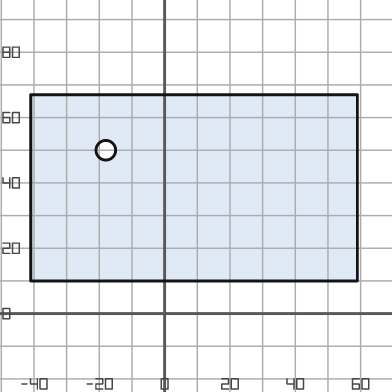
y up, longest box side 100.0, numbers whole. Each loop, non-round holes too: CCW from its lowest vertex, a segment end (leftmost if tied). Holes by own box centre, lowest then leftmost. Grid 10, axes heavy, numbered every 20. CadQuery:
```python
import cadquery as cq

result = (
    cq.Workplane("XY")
    .moveTo(-41.0, 10.0)
    .lineTo(59.0, 10.0)
    .lineTo(59.0, 67.0)
    .lineTo(-41.0, 67.0)
    .close()
    .moveTo(-18.0, 50.0)
    .circle(3.0)
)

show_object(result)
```